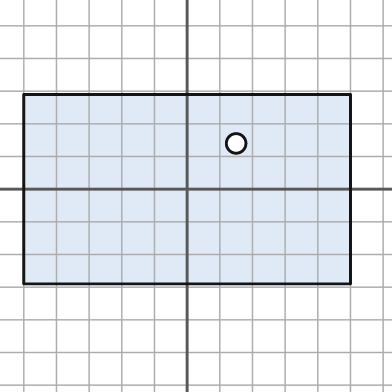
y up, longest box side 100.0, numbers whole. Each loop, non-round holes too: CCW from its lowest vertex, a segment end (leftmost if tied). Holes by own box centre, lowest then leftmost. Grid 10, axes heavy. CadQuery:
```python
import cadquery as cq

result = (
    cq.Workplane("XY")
    .moveTo(-50.0, -29.0)
    .lineTo(50.0, -29.0)
    .lineTo(50.0, 29.0)
    .lineTo(-50.0, 29.0)
    .close()
    .moveTo(15.0, 14.0)
    .circle(3.0)
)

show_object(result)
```